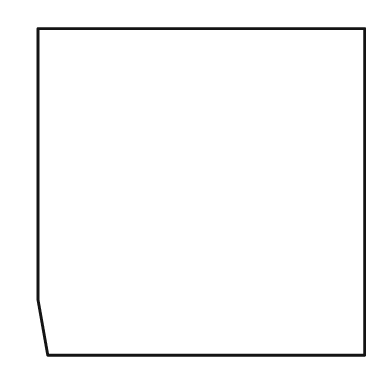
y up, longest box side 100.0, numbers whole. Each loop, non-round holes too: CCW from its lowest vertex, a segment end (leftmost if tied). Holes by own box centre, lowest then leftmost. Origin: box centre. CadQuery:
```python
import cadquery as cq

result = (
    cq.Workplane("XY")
    .moveTo(-47.0, -50.0)
    .lineTo(50.0, -50.0)
    .lineTo(50.0, 50.0)
    .lineTo(-50.0, 50.0)
    .lineTo(-50.0, -33.0)
    .close()
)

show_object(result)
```